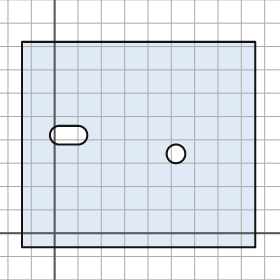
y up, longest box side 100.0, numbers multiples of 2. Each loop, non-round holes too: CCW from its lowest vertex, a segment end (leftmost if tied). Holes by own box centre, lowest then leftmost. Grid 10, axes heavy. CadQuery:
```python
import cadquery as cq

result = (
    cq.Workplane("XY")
    .moveTo(-14.0, -6.0)
    .lineTo(86.0, -6.0)
    .lineTo(86.0, 82.0)
    .lineTo(-14.0, 82.0)
    .close()
    .moveTo(52.0, 34.0)
    .circle(4.0)
    .moveTo(2.0, 38.0)
    .lineTo(10.0, 38.0)
    .threePointArc((14.0, 42.0), (10.0, 46.0))
    .lineTo(2.0, 46.0)
    .threePointArc((-2.0, 42.0), (2.0, 38.0))
    .close()
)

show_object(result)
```